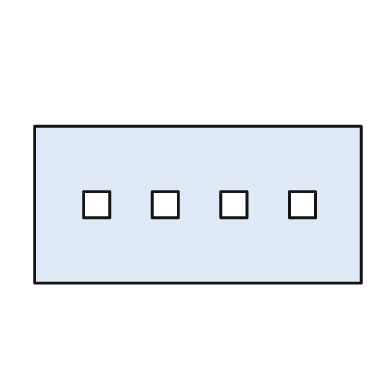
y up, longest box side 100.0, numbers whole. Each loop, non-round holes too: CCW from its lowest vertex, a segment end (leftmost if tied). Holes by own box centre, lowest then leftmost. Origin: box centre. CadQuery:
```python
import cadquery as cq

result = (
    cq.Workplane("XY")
    .moveTo(-50.0, -24.0)
    .lineTo(50.0, -24.0)
    .lineTo(50.0, 24.0)
    .lineTo(-50.0, 24.0)
    .close()
    .moveTo(-35.0, -4.0)
    .lineTo(-27.0, -4.0)
    .lineTo(-27.0, 4.0)
    .lineTo(-35.0, 4.0)
    .close()
    .moveTo(-14.0, -4.0)
    .lineTo(-6.0, -4.0)
    .lineTo(-6.0, 4.0)
    .lineTo(-14.0, 4.0)
    .close()
    .moveTo(7.0, -4.0)
    .lineTo(15.0, -4.0)
    .lineTo(15.0, 4.0)
    .lineTo(7.0, 4.0)
    .close()
    .moveTo(28.0, -4.0)
    .lineTo(36.0, -4.0)
    .lineTo(36.0, 4.0)
    .lineTo(28.0, 4.0)
    .close()
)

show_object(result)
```